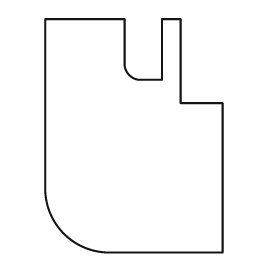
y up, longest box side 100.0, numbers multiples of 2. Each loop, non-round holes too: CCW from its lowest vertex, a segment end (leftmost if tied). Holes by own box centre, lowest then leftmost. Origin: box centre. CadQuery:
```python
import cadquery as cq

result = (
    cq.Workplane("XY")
    .moveTo(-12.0, -50.0)
    .lineTo(38.0, -50.0)
    .lineTo(38.0, 14.0)
    .lineTo(20.0, 14.0)
    .lineTo(20.0, 50.0)
    .lineTo(12.0, 50.0)
    .lineTo(12.0, 24.0)
    .lineTo(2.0, 24.0)
    .threePointArc((-2.0, 26.0), (-4.0, 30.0))
    .lineTo(-4.0, 50.0)
    .lineTo(-38.0, 50.0)
    .lineTo(-38.0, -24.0)
    .threePointArc((-30.0, -42.0), (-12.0, -50.0))
    .close()
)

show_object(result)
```